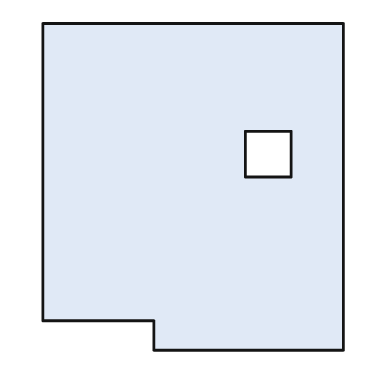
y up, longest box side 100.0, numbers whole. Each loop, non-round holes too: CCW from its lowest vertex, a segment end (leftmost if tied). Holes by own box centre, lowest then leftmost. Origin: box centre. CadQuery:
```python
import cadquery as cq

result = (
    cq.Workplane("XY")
    .moveTo(-12.0, -50.0)
    .lineTo(46.0, -50.0)
    .lineTo(46.0, 50.0)
    .lineTo(-46.0, 50.0)
    .lineTo(-46.0, -41.0)
    .lineTo(-12.0, -41.0)
    .close()
    .moveTo(16.0, 3.0)
    .lineTo(30.0, 3.0)
    .lineTo(30.0, 17.0)
    .lineTo(16.0, 17.0)
    .close()
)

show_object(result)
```